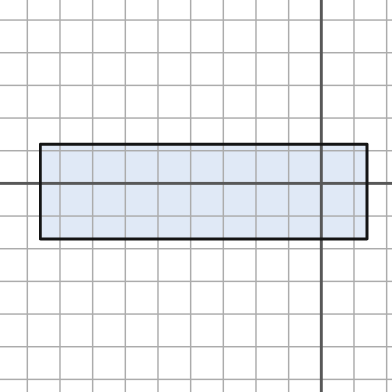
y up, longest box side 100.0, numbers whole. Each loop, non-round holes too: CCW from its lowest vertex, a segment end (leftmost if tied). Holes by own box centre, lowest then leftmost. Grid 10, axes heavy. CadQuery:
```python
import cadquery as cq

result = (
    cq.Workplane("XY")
    .moveTo(-86.0, -17.0)
    .lineTo(14.0, -17.0)
    .lineTo(14.0, 12.0)
    .lineTo(-86.0, 12.0)
    .close()
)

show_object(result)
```